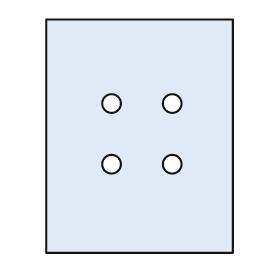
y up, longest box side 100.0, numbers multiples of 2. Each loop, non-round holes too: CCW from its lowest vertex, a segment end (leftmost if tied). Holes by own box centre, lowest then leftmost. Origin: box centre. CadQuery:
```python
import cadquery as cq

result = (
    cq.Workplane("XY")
    .moveTo(-40.0, -50.0)
    .lineTo(40.0, -50.0)
    .lineTo(40.0, 50.0)
    .lineTo(-40.0, 50.0)
    .close()
    .moveTo(-12.0, -12.0)
    .circle(4.0)
    .moveTo(14.0, -12.0)
    .circle(4.0)
    .moveTo(-12.0, 14.0)
    .circle(4.0)
    .moveTo(14.0, 14.0)
    .circle(4.0)
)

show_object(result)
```